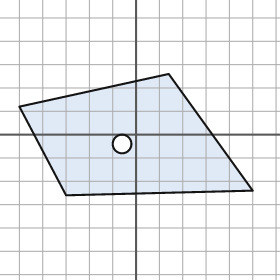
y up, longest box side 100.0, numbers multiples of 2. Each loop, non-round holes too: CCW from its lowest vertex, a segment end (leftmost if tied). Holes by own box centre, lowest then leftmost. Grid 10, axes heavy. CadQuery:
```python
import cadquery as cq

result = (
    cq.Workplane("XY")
    .moveTo(-30.0, -26.0)
    .lineTo(50.0, -24.0)
    .lineTo(14.0, 26.0)
    .lineTo(-50.0, 12.0)
    .close()
    .moveTo(-6.0, -4.0)
    .circle(4.0)
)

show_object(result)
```